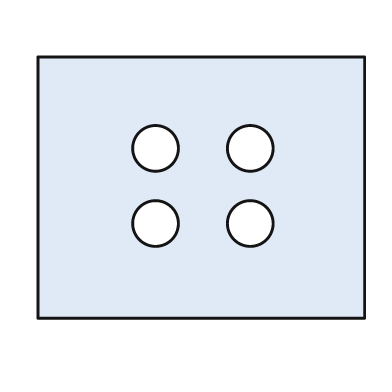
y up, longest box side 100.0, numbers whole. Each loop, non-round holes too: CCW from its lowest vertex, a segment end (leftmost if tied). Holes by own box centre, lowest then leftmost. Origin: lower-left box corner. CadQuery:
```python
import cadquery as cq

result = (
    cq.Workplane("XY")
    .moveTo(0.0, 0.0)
    .lineTo(100.0, 0.0)
    .lineTo(100.0, 80.0)
    .lineTo(0.0, 80.0)
    .close()
    .moveTo(36.0, 29.0)
    .circle(7.0)
    .moveTo(65.0, 29.0)
    .circle(7.0)
    .moveTo(36.0, 52.0)
    .circle(7.0)
    .moveTo(65.0, 52.0)
    .circle(7.0)
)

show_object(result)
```